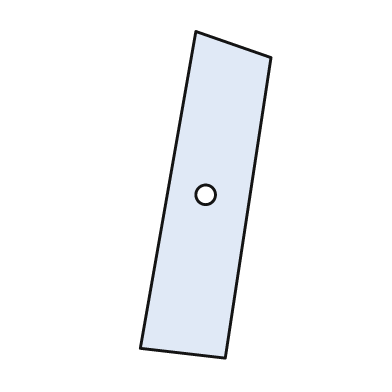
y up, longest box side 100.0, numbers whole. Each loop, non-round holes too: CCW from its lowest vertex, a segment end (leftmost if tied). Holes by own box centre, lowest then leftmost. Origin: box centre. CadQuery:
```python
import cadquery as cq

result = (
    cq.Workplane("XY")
    .moveTo(6.0, -50.0)
    .lineTo(20.0, 42.0)
    .lineTo(-3.0, 50.0)
    .lineTo(-20.0, -47.0)
    .close()
    .moveTo(0.0, 0.0)
    .circle(3.0)
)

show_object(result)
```